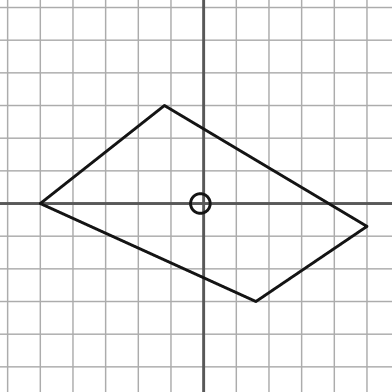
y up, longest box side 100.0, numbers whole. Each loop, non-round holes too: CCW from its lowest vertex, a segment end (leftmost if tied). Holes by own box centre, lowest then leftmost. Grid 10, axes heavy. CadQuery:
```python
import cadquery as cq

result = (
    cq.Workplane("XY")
    .moveTo(16.0, -30.0)
    .lineTo(50.0, -7.0)
    .lineTo(-12.0, 30.0)
    .lineTo(-50.0, 0.0)
    .close()
    .moveTo(-1.0, 0.0)
    .circle(3.0)
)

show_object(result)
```